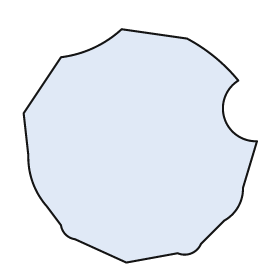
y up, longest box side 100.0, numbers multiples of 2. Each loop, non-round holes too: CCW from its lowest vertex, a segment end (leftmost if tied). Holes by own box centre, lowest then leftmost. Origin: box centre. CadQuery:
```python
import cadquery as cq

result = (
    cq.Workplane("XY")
    .moveTo(-6.0, -50.0)
    .lineTo(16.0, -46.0)
    .threePointArc((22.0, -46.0), (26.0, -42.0))
    .lineTo(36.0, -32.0)
    .threePointArc((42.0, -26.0), (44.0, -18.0))
    .lineTo(50.0, 2.0)
    .threePointArc((36.0, 12.0), (42.0, 28.0))
    .threePointArc((32.0, 38.0), (20.0, 46.0))
    .lineTo(-8.0, 50.0)
    .threePointArc((-20.0, 42.0), (-34.0, 38.0))
    .lineTo(-50.0, 14.0)
    .lineTo(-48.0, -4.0)
    .threePointArc((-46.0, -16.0), (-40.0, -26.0))
    .lineTo(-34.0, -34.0)
    .threePointArc((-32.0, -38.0), (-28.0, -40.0))
    .close()
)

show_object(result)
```